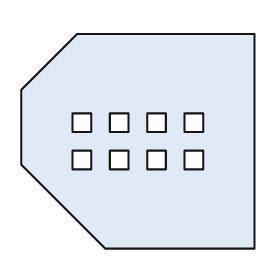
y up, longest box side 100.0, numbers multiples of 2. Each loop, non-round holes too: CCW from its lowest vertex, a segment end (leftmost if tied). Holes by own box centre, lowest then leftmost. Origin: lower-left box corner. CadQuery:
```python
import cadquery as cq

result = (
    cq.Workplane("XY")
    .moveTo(36.0, 0.0)
    .lineTo(100.0, 0.0)
    .lineTo(100.0, 92.0)
    .lineTo(24.0, 92.0)
    .lineTo(0.0, 68.0)
    .lineTo(0.0, 36.0)
    .close()
    .moveTo(22.0, 34.0)
    .lineTo(30.0, 34.0)
    .lineTo(30.0, 42.0)
    .lineTo(22.0, 42.0)
    .close()
    .moveTo(38.0, 34.0)
    .lineTo(46.0, 34.0)
    .lineTo(46.0, 42.0)
    .lineTo(38.0, 42.0)
    .close()
    .moveTo(54.0, 34.0)
    .lineTo(62.0, 34.0)
    .lineTo(62.0, 42.0)
    .lineTo(54.0, 42.0)
    .close()
    .moveTo(70.0, 34.0)
    .lineTo(78.0, 34.0)
    .lineTo(78.0, 42.0)
    .lineTo(70.0, 42.0)
    .close()
    .moveTo(22.0, 50.0)
    .lineTo(30.0, 50.0)
    .lineTo(30.0, 58.0)
    .lineTo(22.0, 58.0)
    .close()
    .moveTo(38.0, 50.0)
    .lineTo(46.0, 50.0)
    .lineTo(46.0, 58.0)
    .lineTo(38.0, 58.0)
    .close()
    .moveTo(54.0, 50.0)
    .lineTo(62.0, 50.0)
    .lineTo(62.0, 58.0)
    .lineTo(54.0, 58.0)
    .close()
    .moveTo(70.0, 50.0)
    .lineTo(78.0, 50.0)
    .lineTo(78.0, 58.0)
    .lineTo(70.0, 58.0)
    .close()
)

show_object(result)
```